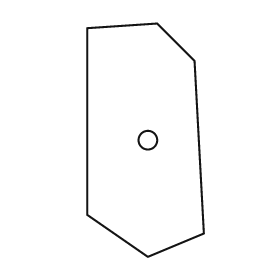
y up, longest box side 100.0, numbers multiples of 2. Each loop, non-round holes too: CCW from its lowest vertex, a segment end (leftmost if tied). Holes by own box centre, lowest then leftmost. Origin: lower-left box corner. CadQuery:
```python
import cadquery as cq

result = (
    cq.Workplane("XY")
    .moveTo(26.0, 0.0)
    .lineTo(50.0, 10.0)
    .lineTo(46.0, 84.0)
    .lineTo(30.0, 100.0)
    .lineTo(0.0, 98.0)
    .lineTo(0.0, 18.0)
    .close()
    .moveTo(26.0, 50.0)
    .circle(4.0)
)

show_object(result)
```